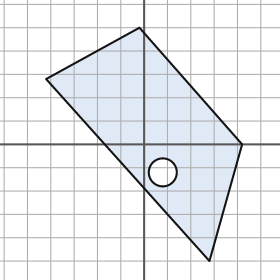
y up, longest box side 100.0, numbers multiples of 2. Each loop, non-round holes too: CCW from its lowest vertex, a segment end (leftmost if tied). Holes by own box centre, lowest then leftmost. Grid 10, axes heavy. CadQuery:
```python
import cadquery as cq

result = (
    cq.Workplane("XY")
    .moveTo(28.0, -50.0)
    .lineTo(42.0, 0.0)
    .lineTo(-2.0, 50.0)
    .lineTo(-42.0, 28.0)
    .close()
    .moveTo(8.0, -12.0)
    .circle(6.0)
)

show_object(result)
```